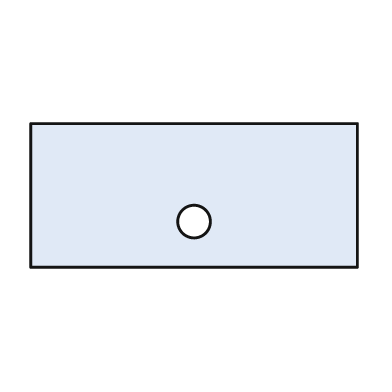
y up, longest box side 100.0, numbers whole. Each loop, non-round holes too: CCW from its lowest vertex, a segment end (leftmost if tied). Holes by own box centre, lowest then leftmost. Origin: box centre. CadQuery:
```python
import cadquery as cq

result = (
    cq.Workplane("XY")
    .moveTo(-50.0, -22.0)
    .lineTo(50.0, -22.0)
    .lineTo(50.0, 22.0)
    .lineTo(-50.0, 22.0)
    .close()
    .moveTo(0.0, -8.0)
    .circle(5.0)
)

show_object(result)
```